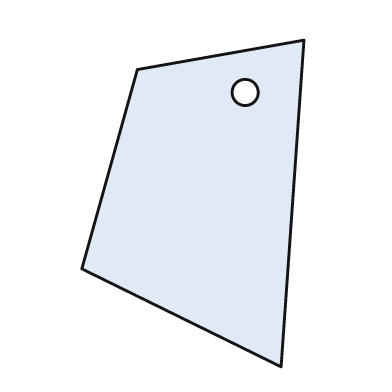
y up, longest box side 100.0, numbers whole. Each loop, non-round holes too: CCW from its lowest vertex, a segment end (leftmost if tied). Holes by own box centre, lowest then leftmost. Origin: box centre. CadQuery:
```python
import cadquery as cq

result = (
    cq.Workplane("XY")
    .moveTo(27.0, -50.0)
    .lineTo(34.0, 50.0)
    .lineTo(-17.0, 41.0)
    .lineTo(-34.0, -20.0)
    .close()
    .moveTo(16.0, 34.0)
    .circle(4.0)
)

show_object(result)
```